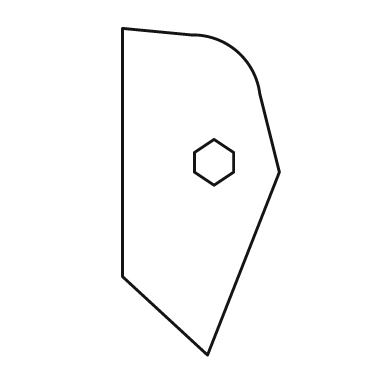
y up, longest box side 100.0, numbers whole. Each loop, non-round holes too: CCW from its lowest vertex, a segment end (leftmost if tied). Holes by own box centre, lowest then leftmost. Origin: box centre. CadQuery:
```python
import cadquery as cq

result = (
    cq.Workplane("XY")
    .moveTo(2.0, -50.0)
    .lineTo(24.0, 6.0)
    .lineTo(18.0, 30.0)
    .threePointArc((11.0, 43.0), (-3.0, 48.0))
    .lineTo(-24.0, 50.0)
    .lineTo(-24.0, -26.0)
    .close()
    .moveTo(4.0, 2.0)
    .lineTo(10.0, 6.0)
    .lineTo(10.0, 12.0)
    .lineTo(4.0, 16.0)
    .lineTo(-2.0, 12.0)
    .lineTo(-2.0, 6.0)
    .close()
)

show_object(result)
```